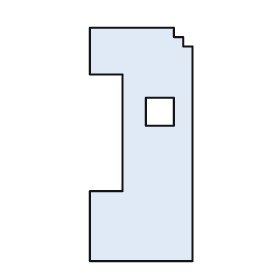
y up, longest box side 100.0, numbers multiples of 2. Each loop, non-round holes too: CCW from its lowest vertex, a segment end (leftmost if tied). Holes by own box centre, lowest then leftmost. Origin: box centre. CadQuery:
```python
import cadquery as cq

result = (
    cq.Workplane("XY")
    .moveTo(-22.0, -50.0)
    .lineTo(22.0, -50.0)
    .lineTo(22.0, 42.0)
    .lineTo(18.0, 42.0)
    .lineTo(18.0, 46.0)
    .lineTo(14.0, 46.0)
    .lineTo(14.0, 50.0)
    .lineTo(-22.0, 50.0)
    .lineTo(-22.0, 30.0)
    .lineTo(-8.0, 30.0)
    .lineTo(-8.0, -20.0)
    .lineTo(-22.0, -20.0)
    .close()
    .moveTo(2.0, 8.0)
    .lineTo(14.0, 8.0)
    .lineTo(14.0, 20.0)
    .lineTo(2.0, 20.0)
    .close()
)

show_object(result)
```